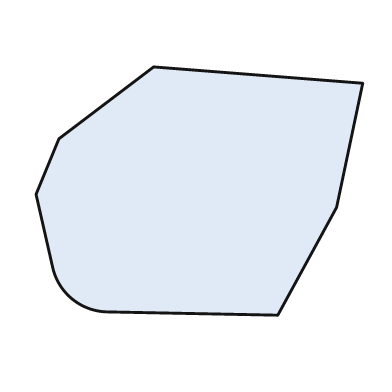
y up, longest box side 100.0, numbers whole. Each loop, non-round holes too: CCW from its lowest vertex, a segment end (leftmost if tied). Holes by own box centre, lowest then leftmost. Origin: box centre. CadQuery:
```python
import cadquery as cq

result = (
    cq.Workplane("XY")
    .moveTo(24.0, -38.0)
    .lineTo(42.0, -5.0)
    .lineTo(50.0, 33.0)
    .lineTo(-14.0, 38.0)
    .lineTo(-43.0, 16.0)
    .lineTo(-50.0, -1.0)
    .lineTo(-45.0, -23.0)
    .threePointArc((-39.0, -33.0), (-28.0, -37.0))
    .close()
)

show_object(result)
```